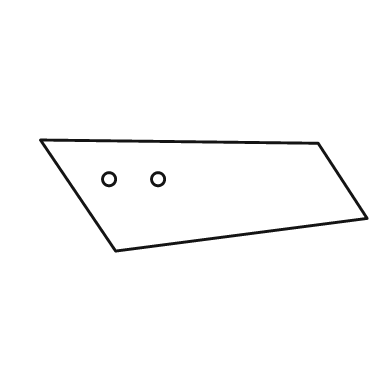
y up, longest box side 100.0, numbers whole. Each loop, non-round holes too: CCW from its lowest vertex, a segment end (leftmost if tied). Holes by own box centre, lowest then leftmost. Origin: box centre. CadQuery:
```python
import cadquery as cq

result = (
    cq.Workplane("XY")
    .moveTo(-27.0, -17.0)
    .lineTo(50.0, -7.0)
    .lineTo(35.0, 16.0)
    .lineTo(-50.0, 17.0)
    .close()
    .moveTo(-29.0, 5.0)
    .circle(2.0)
    .moveTo(-14.0, 5.0)
    .circle(2.0)
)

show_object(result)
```